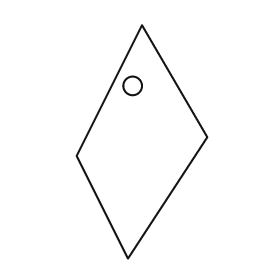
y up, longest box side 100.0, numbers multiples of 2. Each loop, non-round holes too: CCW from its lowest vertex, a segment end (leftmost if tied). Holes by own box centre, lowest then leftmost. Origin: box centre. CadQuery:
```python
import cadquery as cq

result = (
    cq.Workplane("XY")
    .moveTo(-6.0, -50.0)
    .lineTo(28.0, 2.0)
    .lineTo(0.0, 50.0)
    .lineTo(-28.0, -6.0)
    .close()
    .moveTo(-4.0, 24.0)
    .circle(4.0)
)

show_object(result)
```